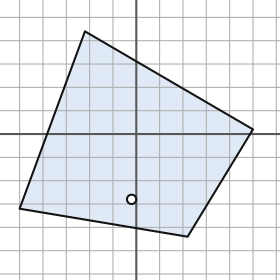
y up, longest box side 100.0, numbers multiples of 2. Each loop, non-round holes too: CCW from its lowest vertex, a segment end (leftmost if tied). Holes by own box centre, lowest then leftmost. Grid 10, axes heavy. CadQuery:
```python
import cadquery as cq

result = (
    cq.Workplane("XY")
    .moveTo(22.0, -44.0)
    .lineTo(50.0, 2.0)
    .lineTo(-22.0, 44.0)
    .lineTo(-50.0, -32.0)
    .close()
    .moveTo(-2.0, -28.0)
    .circle(2.0)
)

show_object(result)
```